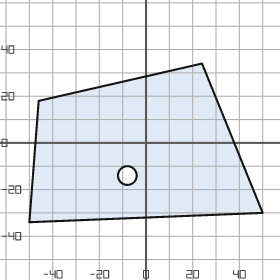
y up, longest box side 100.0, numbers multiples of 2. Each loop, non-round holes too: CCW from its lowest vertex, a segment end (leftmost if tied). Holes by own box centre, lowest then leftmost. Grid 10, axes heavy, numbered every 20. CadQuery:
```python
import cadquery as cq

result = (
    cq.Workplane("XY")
    .moveTo(-50.0, -34.0)
    .lineTo(50.0, -30.0)
    .lineTo(24.0, 34.0)
    .lineTo(-46.0, 18.0)
    .close()
    .moveTo(-8.0, -14.0)
    .circle(4.0)
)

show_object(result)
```